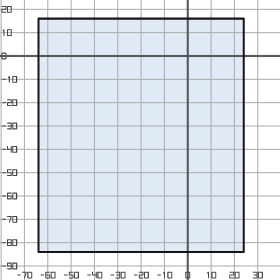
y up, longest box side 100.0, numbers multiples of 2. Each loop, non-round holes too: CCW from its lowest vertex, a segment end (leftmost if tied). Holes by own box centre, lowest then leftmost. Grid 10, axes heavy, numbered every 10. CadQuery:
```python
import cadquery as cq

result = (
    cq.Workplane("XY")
    .moveTo(-64.0, -84.0)
    .lineTo(24.0, -84.0)
    .lineTo(24.0, 16.0)
    .lineTo(-64.0, 16.0)
    .close()
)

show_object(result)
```